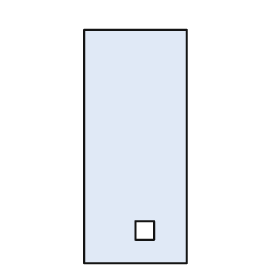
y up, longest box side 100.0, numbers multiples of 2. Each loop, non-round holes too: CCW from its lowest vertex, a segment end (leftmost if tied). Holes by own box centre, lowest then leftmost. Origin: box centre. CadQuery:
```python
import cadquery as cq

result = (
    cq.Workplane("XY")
    .moveTo(-22.0, -50.0)
    .lineTo(22.0, -50.0)
    .lineTo(22.0, 50.0)
    .lineTo(-22.0, 50.0)
    .close()
    .moveTo(0.0, -40.0)
    .lineTo(8.0, -40.0)
    .lineTo(8.0, -32.0)
    .lineTo(0.0, -32.0)
    .close()
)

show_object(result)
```